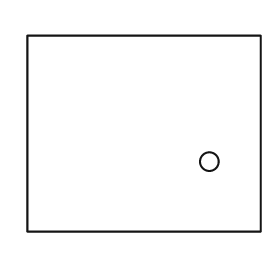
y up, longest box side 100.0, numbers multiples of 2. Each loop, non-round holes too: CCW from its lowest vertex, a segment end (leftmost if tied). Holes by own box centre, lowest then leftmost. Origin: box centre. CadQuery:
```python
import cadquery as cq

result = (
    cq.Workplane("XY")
    .moveTo(-50.0, -42.0)
    .lineTo(50.0, -42.0)
    .lineTo(50.0, 42.0)
    .lineTo(-50.0, 42.0)
    .close()
    .moveTo(28.0, -12.0)
    .circle(4.0)
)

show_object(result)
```